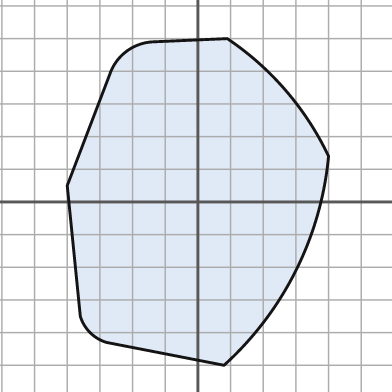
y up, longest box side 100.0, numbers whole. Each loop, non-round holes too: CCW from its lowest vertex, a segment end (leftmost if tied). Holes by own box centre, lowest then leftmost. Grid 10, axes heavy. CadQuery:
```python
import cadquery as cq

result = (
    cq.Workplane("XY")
    .moveTo(8.0, -50.0)
    .threePointArc((30.0, -21.0), (40.0, 14.0))
    .threePointArc((27.0, 34.0), (9.0, 50.0))
    .lineTo(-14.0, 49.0)
    .threePointArc((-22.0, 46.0), (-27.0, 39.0))
    .lineTo(-40.0, 5.0)
    .lineTo(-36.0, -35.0)
    .threePointArc((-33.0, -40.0), (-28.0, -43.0))
    .close()
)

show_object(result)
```